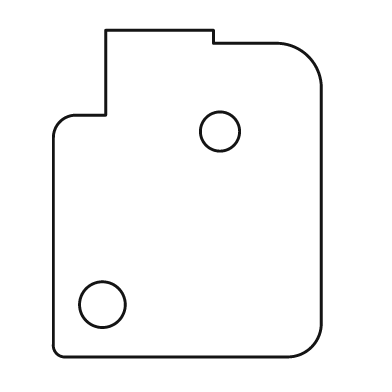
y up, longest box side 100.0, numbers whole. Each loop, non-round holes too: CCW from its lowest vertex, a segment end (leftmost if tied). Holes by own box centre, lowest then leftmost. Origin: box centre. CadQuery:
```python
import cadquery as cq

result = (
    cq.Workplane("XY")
    .moveTo(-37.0, -50.0)
    .lineTo(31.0, -50.0)
    .threePointArc((38.0, -47.0), (41.0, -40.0))
    .lineTo(41.0, 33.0)
    .threePointArc((37.0, 42.0), (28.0, 46.0))
    .lineTo(8.0, 46.0)
    .lineTo(8.0, 50.0)
    .lineTo(-25.0, 50.0)
    .lineTo(-25.0, 24.0)
    .lineTo(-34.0, 24.0)
    .threePointArc((-39.0, 22.0), (-41.0, 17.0))
    .lineTo(-41.0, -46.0)
    .threePointArc((-40.0, -49.0), (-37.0, -50.0))
    .close()
    .moveTo(-26.0, -34.0)
    .circle(7.0)
    .moveTo(10.0, 19.0)
    .circle(6.0)
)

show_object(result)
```